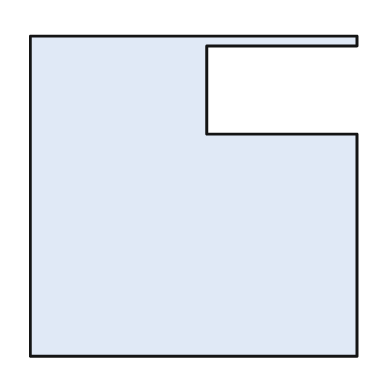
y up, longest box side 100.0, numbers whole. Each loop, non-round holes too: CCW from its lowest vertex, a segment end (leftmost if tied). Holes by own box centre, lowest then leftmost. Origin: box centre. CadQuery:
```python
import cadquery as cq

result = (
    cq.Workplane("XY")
    .moveTo(-50.0, -49.0)
    .lineTo(50.0, -49.0)
    .lineTo(50.0, 19.0)
    .lineTo(4.0, 19.0)
    .lineTo(4.0, 46.0)
    .lineTo(50.0, 46.0)
    .lineTo(50.0, 49.0)
    .lineTo(-50.0, 49.0)
    .close()
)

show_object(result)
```